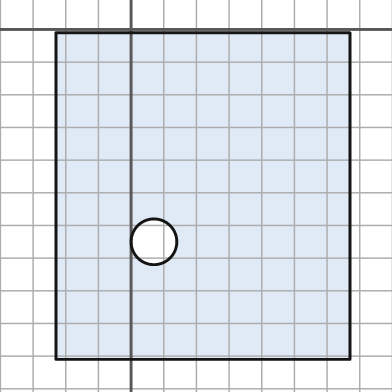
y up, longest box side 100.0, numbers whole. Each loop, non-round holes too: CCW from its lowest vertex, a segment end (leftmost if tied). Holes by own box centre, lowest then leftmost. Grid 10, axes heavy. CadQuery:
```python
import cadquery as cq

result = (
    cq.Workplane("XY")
    .moveTo(-23.0, -101.0)
    .lineTo(67.0, -101.0)
    .lineTo(67.0, -1.0)
    .lineTo(-23.0, -1.0)
    .close()
    .moveTo(7.0, -65.0)
    .circle(7.0)
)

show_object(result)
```